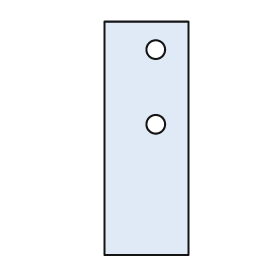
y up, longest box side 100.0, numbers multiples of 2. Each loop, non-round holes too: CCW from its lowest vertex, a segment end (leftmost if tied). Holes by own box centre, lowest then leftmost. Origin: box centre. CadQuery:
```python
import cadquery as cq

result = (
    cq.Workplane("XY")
    .moveTo(-18.0, -50.0)
    .lineTo(18.0, -50.0)
    .lineTo(18.0, 50.0)
    .lineTo(-18.0, 50.0)
    .close()
    .moveTo(4.0, 6.0)
    .circle(4.0)
    .moveTo(4.0, 38.0)
    .circle(4.0)
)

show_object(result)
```